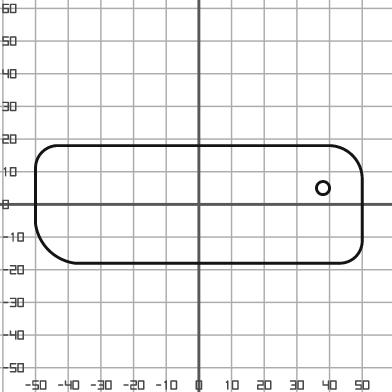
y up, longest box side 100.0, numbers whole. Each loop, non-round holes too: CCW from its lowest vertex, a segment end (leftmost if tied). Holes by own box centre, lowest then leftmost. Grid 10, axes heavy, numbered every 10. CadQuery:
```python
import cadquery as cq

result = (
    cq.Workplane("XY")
    .moveTo(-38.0, -18.0)
    .lineTo(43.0, -18.0)
    .threePointArc((48.0, -16.0), (50.0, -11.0))
    .lineTo(50.0, 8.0)
    .threePointArc((47.0, 15.0), (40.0, 18.0))
    .lineTo(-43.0, 18.0)
    .threePointArc((-48.0, 16.0), (-50.0, 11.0))
    .lineTo(-50.0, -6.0)
    .threePointArc((-46.0, -14.0), (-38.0, -18.0))
    .close()
    .moveTo(38.0, 5.0)
    .circle(2.0)
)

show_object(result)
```